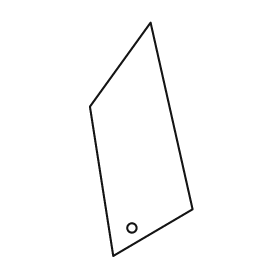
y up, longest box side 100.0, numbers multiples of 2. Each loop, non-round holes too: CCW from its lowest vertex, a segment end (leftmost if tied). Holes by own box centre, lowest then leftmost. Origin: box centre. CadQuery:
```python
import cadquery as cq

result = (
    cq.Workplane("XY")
    .moveTo(-12.0, -50.0)
    .lineTo(22.0, -30.0)
    .lineTo(4.0, 50.0)
    .lineTo(-22.0, 14.0)
    .close()
    .moveTo(-4.0, -38.0)
    .circle(2.0)
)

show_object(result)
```